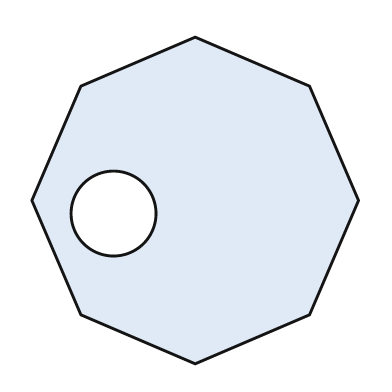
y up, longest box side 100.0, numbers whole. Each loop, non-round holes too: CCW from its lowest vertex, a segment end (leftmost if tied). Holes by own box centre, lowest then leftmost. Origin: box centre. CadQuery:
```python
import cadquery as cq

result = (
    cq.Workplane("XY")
    .moveTo(0.0, -50.0)
    .lineTo(35.0, -35.0)
    .lineTo(50.0, 0.0)
    .lineTo(35.0, 35.0)
    .lineTo(0.0, 50.0)
    .lineTo(-35.0, 35.0)
    .lineTo(-50.0, 0.0)
    .lineTo(-35.0, -35.0)
    .close()
    .moveTo(-25.0, -4.0)
    .circle(13.0)
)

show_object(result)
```